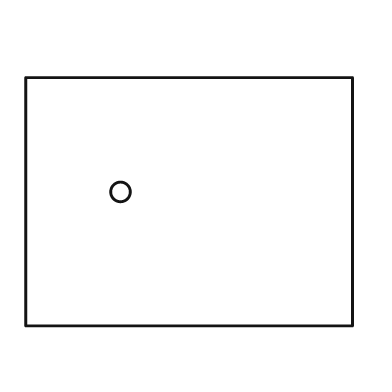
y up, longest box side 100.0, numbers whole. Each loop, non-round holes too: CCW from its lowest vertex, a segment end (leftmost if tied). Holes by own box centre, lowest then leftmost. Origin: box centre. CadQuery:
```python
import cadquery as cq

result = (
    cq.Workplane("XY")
    .moveTo(-50.0, -38.0)
    .lineTo(50.0, -38.0)
    .lineTo(50.0, 38.0)
    .lineTo(-50.0, 38.0)
    .close()
    .moveTo(-21.0, 3.0)
    .circle(3.0)
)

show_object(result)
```